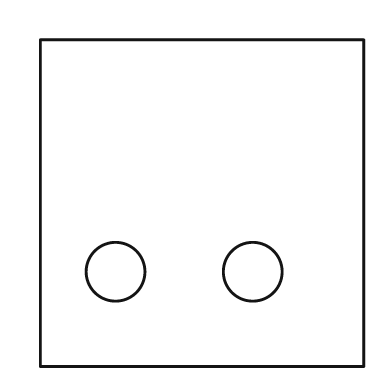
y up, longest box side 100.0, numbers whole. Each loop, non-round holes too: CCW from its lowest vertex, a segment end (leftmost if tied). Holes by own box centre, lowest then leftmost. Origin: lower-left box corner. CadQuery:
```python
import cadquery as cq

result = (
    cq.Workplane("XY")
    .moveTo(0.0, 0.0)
    .lineTo(99.0, 0.0)
    .lineTo(99.0, 100.0)
    .lineTo(0.0, 100.0)
    .close()
    .moveTo(23.0, 29.0)
    .circle(9.0)
    .moveTo(65.0, 29.0)
    .circle(9.0)
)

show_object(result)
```